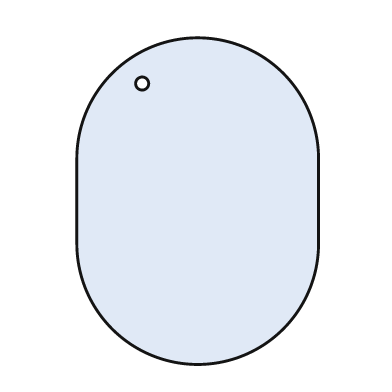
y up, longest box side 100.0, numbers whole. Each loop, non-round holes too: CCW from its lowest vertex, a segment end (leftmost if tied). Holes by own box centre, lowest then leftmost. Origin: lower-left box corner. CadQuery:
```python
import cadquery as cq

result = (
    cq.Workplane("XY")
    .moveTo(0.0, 37.0)
    .threePointArc((37.0, 0.0), (74.0, 37.0))
    .lineTo(74.0, 63.0)
    .threePointArc((37.0, 100.0), (0.0, 63.0))
    .close()
    .moveTo(20.0, 86.0)
    .circle(2.0)
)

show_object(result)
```